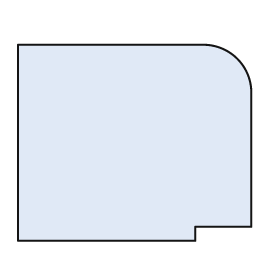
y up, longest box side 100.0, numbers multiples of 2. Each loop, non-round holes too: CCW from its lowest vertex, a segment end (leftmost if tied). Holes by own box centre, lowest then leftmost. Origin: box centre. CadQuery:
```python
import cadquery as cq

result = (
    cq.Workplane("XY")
    .moveTo(-50.0, -42.0)
    .lineTo(26.0, -42.0)
    .lineTo(26.0, -36.0)
    .lineTo(50.0, -36.0)
    .lineTo(50.0, 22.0)
    .threePointArc((44.0, 36.0), (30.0, 42.0))
    .lineTo(-50.0, 42.0)
    .close()
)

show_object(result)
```